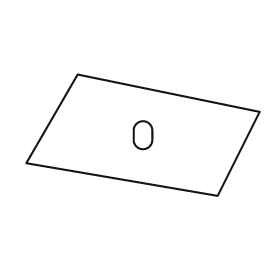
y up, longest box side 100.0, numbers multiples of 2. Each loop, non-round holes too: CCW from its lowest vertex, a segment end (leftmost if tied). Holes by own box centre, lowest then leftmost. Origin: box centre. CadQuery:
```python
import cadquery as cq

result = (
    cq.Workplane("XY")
    .moveTo(32.0, -26.0)
    .lineTo(50.0, 10.0)
    .lineTo(-28.0, 26.0)
    .lineTo(-50.0, -12.0)
    .close()
    .moveTo(-4.0, -2.0)
    .threePointArc((0.0, -6.0), (4.0, -2.0))
    .lineTo(4.0, 2.0)
    .threePointArc((0.0, 6.0), (-4.0, 2.0))
    .close()
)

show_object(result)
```